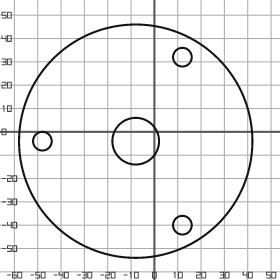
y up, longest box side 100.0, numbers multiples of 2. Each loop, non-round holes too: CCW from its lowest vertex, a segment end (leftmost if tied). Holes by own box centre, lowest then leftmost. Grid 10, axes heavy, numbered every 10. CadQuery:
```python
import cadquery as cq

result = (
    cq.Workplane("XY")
    .moveTo(-8.0, -4.0)
    .circle(50.0)
    .moveTo(12.0, -40.0)
    .circle(4.0)
    .moveTo(-48.0, -4.0)
    .circle(4.0)
    .moveTo(-8.0, -4.0)
    .circle(10.0)
    .moveTo(12.0, 32.0)
    .circle(4.0)
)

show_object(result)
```